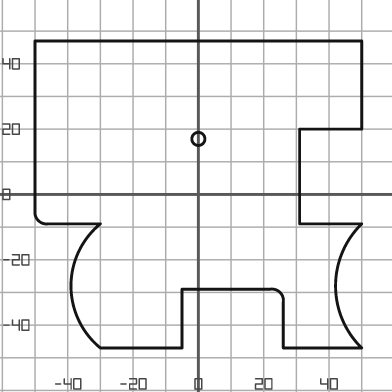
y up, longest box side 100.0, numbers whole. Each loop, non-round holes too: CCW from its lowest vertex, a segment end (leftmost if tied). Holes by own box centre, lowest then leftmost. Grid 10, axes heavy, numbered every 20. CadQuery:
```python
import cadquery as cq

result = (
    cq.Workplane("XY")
    .moveTo(-30.0, -47.0)
    .lineTo(-5.0, -47.0)
    .lineTo(-5.0, -29.0)
    .lineTo(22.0, -29.0)
    .threePointArc((25.0, -30.0), (26.0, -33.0))
    .lineTo(26.0, -47.0)
    .lineTo(50.0, -47.0)
    .threePointArc((42.0, -28.0), (50.0, -9.0))
    .lineTo(31.0, -9.0)
    .lineTo(31.0, 20.0)
    .lineTo(50.0, 20.0)
    .lineTo(50.0, 47.0)
    .lineTo(-50.0, 47.0)
    .lineTo(-50.0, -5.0)
    .threePointArc((-49.0, -8.0), (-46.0, -9.0))
    .lineTo(-30.0, -9.0)
    .threePointArc((-39.0, -28.0), (-30.0, -47.0))
    .close()
    .moveTo(0.0, 17.0)
    .circle(2.0)
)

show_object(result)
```